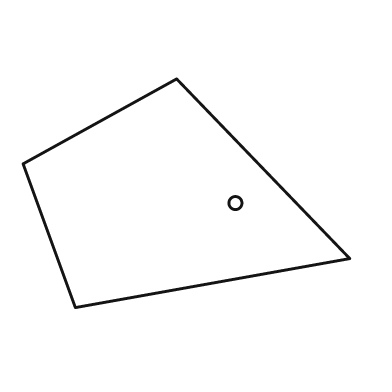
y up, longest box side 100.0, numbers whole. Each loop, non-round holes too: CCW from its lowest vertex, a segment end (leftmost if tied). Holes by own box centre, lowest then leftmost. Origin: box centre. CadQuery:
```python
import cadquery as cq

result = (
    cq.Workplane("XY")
    .moveTo(-34.0, -35.0)
    .lineTo(50.0, -20.0)
    .lineTo(-3.0, 35.0)
    .lineTo(-50.0, 9.0)
    .close()
    .moveTo(15.0, -3.0)
    .circle(2.0)
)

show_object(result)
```